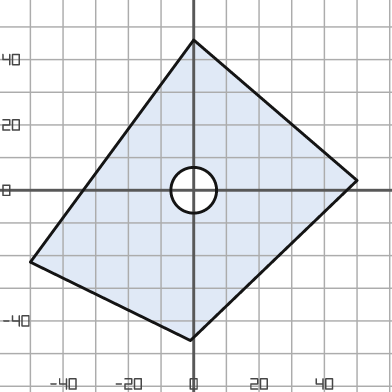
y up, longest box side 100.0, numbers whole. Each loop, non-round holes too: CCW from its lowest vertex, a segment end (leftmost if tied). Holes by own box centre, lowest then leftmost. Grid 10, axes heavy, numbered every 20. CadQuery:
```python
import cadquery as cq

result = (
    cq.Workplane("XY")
    .moveTo(-1.0, -46.0)
    .lineTo(50.0, 3.0)
    .lineTo(0.0, 46.0)
    .lineTo(-50.0, -22.0)
    .close()
    .moveTo(0.0, 0.0)
    .circle(7.0)
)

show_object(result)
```